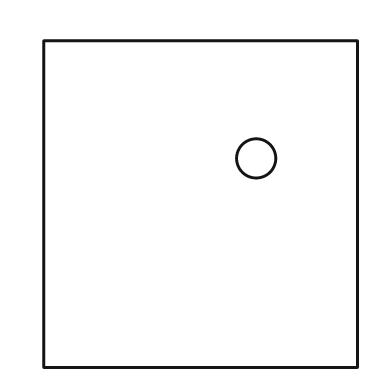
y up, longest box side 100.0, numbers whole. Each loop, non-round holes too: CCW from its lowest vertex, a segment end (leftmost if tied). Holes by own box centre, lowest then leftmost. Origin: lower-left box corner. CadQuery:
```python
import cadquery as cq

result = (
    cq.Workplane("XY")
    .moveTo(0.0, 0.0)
    .lineTo(96.0, 0.0)
    .lineTo(96.0, 100.0)
    .lineTo(0.0, 100.0)
    .close()
    .moveTo(65.0, 64.0)
    .circle(6.0)
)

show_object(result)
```